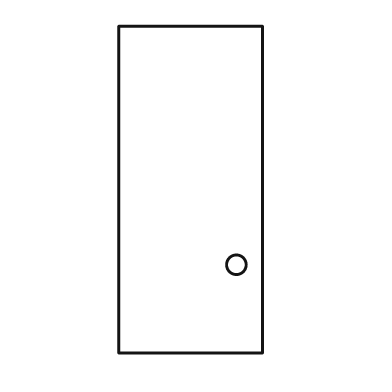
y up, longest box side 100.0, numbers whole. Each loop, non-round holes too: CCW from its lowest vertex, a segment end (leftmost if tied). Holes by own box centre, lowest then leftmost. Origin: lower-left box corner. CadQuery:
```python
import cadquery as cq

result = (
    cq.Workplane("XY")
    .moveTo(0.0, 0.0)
    .lineTo(44.0, 0.0)
    .lineTo(44.0, 100.0)
    .lineTo(0.0, 100.0)
    .close()
    .moveTo(36.0, 27.0)
    .circle(3.0)
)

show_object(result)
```